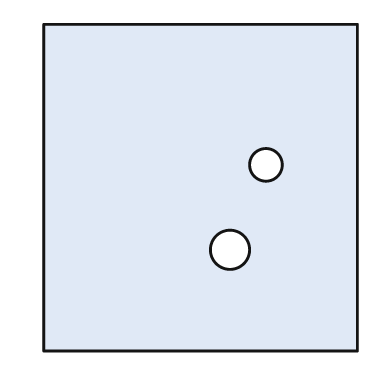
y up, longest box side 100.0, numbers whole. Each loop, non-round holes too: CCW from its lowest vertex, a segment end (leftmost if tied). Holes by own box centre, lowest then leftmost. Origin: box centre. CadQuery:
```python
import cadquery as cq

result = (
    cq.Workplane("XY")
    .moveTo(-48.0, -50.0)
    .lineTo(48.0, -50.0)
    .lineTo(48.0, 50.0)
    .lineTo(-48.0, 50.0)
    .close()
    .moveTo(9.0, -19.0)
    .circle(6.0)
    .moveTo(20.0, 7.0)
    .circle(5.0)
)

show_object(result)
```